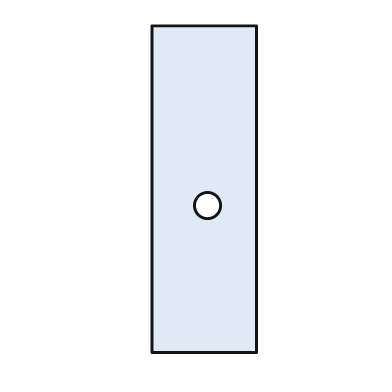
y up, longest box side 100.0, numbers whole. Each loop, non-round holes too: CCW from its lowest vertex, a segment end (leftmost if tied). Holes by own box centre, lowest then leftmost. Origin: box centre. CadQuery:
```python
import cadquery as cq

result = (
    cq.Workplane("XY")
    .moveTo(-16.0, -50.0)
    .lineTo(16.0, -50.0)
    .lineTo(16.0, 50.0)
    .lineTo(-16.0, 50.0)
    .close()
    .moveTo(1.0, -5.0)
    .circle(4.0)
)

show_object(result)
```